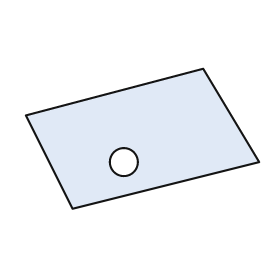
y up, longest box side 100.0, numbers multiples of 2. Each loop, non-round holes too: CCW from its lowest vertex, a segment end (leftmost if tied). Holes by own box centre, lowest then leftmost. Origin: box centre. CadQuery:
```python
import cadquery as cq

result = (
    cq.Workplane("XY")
    .moveTo(-30.0, -30.0)
    .lineTo(50.0, -10.0)
    .lineTo(26.0, 30.0)
    .lineTo(-50.0, 10.0)
    .close()
    .moveTo(-8.0, -10.0)
    .circle(6.0)
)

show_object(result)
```